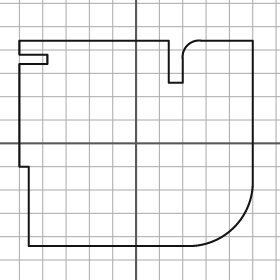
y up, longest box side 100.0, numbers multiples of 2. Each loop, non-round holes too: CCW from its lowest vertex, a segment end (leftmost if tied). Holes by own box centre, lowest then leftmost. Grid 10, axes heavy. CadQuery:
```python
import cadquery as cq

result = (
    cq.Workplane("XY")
    .moveTo(-46.0, -44.0)
    .lineTo(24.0, -44.0)
    .threePointArc((42.0, -36.0), (50.0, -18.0))
    .lineTo(50.0, 44.0)
    .lineTo(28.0, 44.0)
    .threePointArc((22.0, 42.0), (20.0, 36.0))
    .lineTo(20.0, 26.0)
    .lineTo(14.0, 26.0)
    .lineTo(14.0, 44.0)
    .lineTo(-50.0, 44.0)
    .lineTo(-50.0, 38.0)
    .lineTo(-38.0, 38.0)
    .lineTo(-38.0, 34.0)
    .lineTo(-50.0, 34.0)
    .lineTo(-50.0, -10.0)
    .lineTo(-46.0, -10.0)
    .close()
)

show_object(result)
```